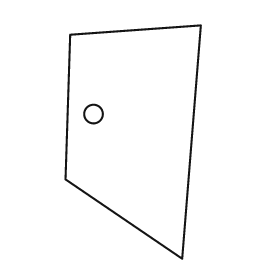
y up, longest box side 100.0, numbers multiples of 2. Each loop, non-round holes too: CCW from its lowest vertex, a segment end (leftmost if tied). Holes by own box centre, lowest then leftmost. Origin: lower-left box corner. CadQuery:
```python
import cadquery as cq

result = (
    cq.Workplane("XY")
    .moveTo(50.0, 0.0)
    .lineTo(58.0, 100.0)
    .lineTo(2.0, 96.0)
    .lineTo(0.0, 34.0)
    .close()
    .moveTo(12.0, 62.0)
    .circle(4.0)
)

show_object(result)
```